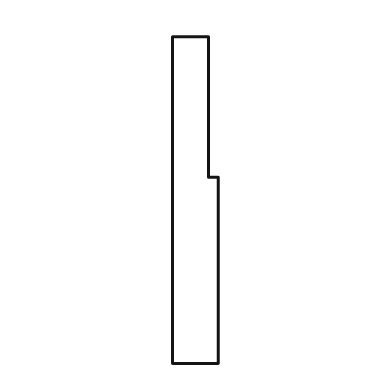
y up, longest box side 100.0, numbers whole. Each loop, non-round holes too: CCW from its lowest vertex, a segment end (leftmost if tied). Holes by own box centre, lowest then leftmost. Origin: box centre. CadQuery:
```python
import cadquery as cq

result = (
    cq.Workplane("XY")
    .moveTo(-7.0, -50.0)
    .lineTo(7.0, -50.0)
    .lineTo(7.0, 7.0)
    .lineTo(4.0, 7.0)
    .lineTo(4.0, 50.0)
    .lineTo(-7.0, 50.0)
    .close()
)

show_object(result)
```